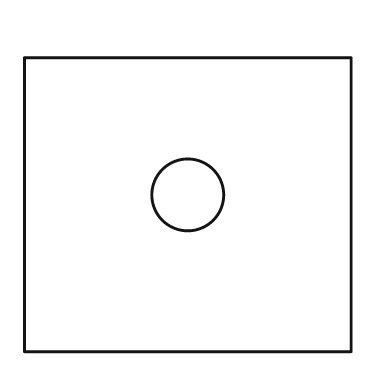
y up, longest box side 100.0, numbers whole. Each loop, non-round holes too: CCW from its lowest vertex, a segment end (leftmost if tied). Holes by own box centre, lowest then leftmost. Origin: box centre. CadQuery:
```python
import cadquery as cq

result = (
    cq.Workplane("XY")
    .moveTo(-50.0, -45.0)
    .lineTo(50.0, -45.0)
    .lineTo(50.0, 45.0)
    .lineTo(-50.0, 45.0)
    .close()
    .moveTo(0.0, 3.0)
    .circle(11.0)
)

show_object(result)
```